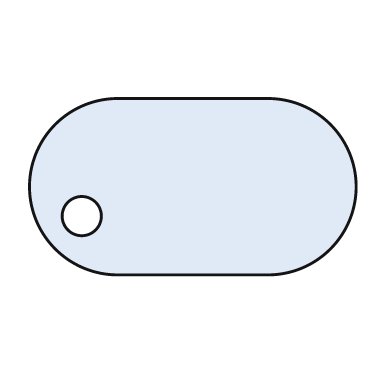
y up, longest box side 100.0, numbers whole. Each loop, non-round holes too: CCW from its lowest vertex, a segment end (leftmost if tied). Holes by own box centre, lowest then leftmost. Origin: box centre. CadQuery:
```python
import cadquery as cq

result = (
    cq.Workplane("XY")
    .moveTo(-23.0, -27.0)
    .lineTo(23.0, -27.0)
    .threePointArc((50.0, 0.0), (23.0, 27.0))
    .lineTo(-23.0, 27.0)
    .threePointArc((-50.0, 0.0), (-23.0, -27.0))
    .close()
    .moveTo(-34.0, -9.0)
    .circle(6.0)
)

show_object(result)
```